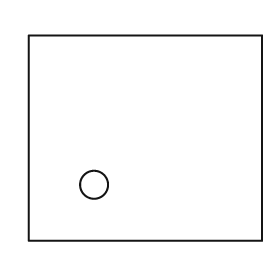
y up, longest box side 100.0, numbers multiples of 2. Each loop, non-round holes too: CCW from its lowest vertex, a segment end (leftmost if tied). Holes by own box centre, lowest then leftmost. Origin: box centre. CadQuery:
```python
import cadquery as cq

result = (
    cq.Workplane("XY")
    .moveTo(-50.0, -44.0)
    .lineTo(50.0, -44.0)
    .lineTo(50.0, 44.0)
    .lineTo(-50.0, 44.0)
    .close()
    .moveTo(-22.0, -20.0)
    .circle(6.0)
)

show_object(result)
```